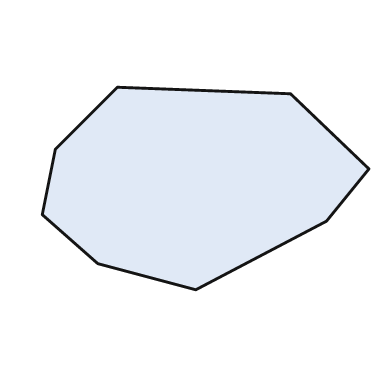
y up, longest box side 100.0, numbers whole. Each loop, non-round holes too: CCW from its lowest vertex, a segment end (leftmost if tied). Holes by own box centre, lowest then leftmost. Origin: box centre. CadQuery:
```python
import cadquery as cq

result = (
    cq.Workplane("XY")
    .moveTo(-3.0, -31.0)
    .lineTo(37.0, -10.0)
    .lineTo(50.0, 6.0)
    .lineTo(26.0, 29.0)
    .lineTo(-27.0, 31.0)
    .lineTo(-46.0, 12.0)
    .lineTo(-50.0, -8.0)
    .lineTo(-33.0, -23.0)
    .close()
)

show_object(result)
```